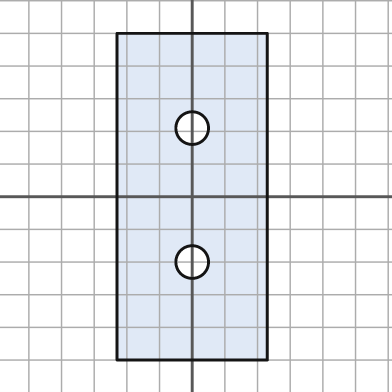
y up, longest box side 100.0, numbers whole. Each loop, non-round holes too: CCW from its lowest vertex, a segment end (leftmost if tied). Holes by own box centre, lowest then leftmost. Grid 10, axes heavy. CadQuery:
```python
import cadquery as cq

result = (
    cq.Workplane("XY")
    .moveTo(-23.0, -50.0)
    .lineTo(23.0, -50.0)
    .lineTo(23.0, 50.0)
    .lineTo(-23.0, 50.0)
    .close()
    .moveTo(0.0, -20.0)
    .circle(5.0)
    .moveTo(0.0, 21.0)
    .circle(5.0)
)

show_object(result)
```